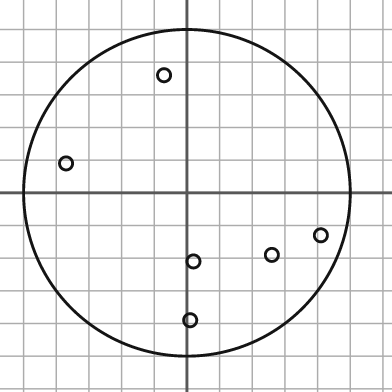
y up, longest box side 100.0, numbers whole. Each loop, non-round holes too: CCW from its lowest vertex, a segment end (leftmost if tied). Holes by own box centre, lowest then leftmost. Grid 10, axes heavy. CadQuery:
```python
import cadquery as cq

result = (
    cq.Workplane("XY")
    .moveTo(0.0, 0.0)
    .circle(50.0)
    .moveTo(1.0, -39.0)
    .circle(2.0)
    .moveTo(2.0, -21.0)
    .circle(2.0)
    .moveTo(26.0, -19.0)
    .circle(2.0)
    .moveTo(41.0, -13.0)
    .circle(2.0)
    .moveTo(-37.0, 9.0)
    .circle(2.0)
    .moveTo(-7.0, 36.0)
    .circle(2.0)
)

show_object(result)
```